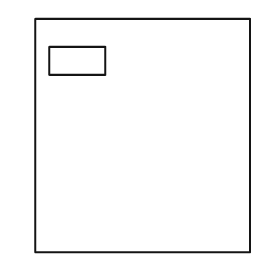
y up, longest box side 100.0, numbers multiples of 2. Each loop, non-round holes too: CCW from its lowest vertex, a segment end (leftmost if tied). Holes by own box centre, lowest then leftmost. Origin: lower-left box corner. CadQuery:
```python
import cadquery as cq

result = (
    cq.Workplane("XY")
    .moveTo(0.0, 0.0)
    .lineTo(92.0, 0.0)
    .lineTo(92.0, 100.0)
    .lineTo(0.0, 100.0)
    .close()
    .moveTo(6.0, 76.0)
    .lineTo(30.0, 76.0)
    .lineTo(30.0, 88.0)
    .lineTo(6.0, 88.0)
    .close()
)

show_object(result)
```